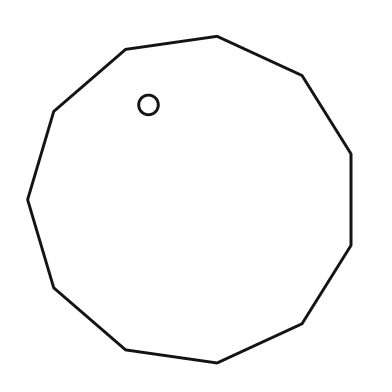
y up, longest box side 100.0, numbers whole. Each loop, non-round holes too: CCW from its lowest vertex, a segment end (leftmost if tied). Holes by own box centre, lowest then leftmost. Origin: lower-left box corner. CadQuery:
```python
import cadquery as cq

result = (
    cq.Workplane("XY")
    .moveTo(58.0, 0.0)
    .lineTo(84.0, 12.0)
    .lineTo(99.0, 36.0)
    .lineTo(99.0, 64.0)
    .lineTo(84.0, 88.0)
    .lineTo(58.0, 100.0)
    .lineTo(30.0, 96.0)
    .lineTo(8.0, 77.0)
    .lineTo(0.0, 50.0)
    .lineTo(8.0, 23.0)
    .lineTo(30.0, 4.0)
    .close()
    .moveTo(37.0, 79.0)
    .circle(3.0)
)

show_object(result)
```